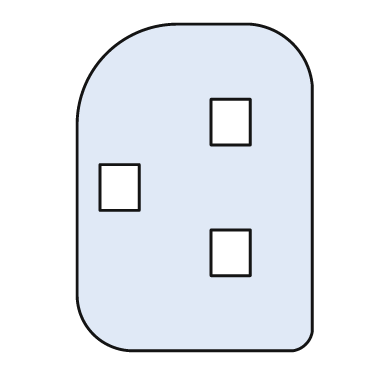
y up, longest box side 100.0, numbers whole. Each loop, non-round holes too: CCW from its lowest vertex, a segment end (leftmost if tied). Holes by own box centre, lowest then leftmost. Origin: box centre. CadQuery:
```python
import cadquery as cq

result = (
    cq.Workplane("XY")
    .moveTo(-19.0, -50.0)
    .lineTo(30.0, -50.0)
    .threePointArc((34.0, -48.0), (36.0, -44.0))
    .lineTo(36.0, 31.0)
    .threePointArc((30.0, 44.0), (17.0, 50.0))
    .lineTo(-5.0, 50.0)
    .threePointArc((-27.0, 41.0), (-36.0, 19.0))
    .lineTo(-36.0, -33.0)
    .threePointArc((-31.0, -45.0), (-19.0, -50.0))
    .close()
    .moveTo(5.0, -27.0)
    .lineTo(17.0, -27.0)
    .lineTo(17.0, -13.0)
    .lineTo(5.0, -13.0)
    .close()
    .moveTo(-29.0, -7.0)
    .lineTo(-17.0, -7.0)
    .lineTo(-17.0, 7.0)
    .lineTo(-29.0, 7.0)
    .close()
    .moveTo(5.0, 13.0)
    .lineTo(17.0, 13.0)
    .lineTo(17.0, 27.0)
    .lineTo(5.0, 27.0)
    .close()
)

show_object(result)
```